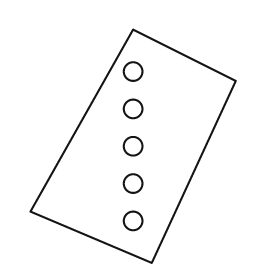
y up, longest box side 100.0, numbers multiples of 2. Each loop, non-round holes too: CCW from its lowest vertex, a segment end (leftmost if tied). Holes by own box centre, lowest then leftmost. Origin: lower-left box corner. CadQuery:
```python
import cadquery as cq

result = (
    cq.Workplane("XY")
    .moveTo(52.0, 0.0)
    .lineTo(88.0, 78.0)
    .lineTo(44.0, 100.0)
    .lineTo(0.0, 22.0)
    .close()
    .moveTo(44.0, 18.0)
    .circle(4.0)
    .moveTo(44.0, 34.0)
    .circle(4.0)
    .moveTo(44.0, 50.0)
    .circle(4.0)
    .moveTo(44.0, 66.0)
    .circle(4.0)
    .moveTo(44.0, 82.0)
    .circle(4.0)
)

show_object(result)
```